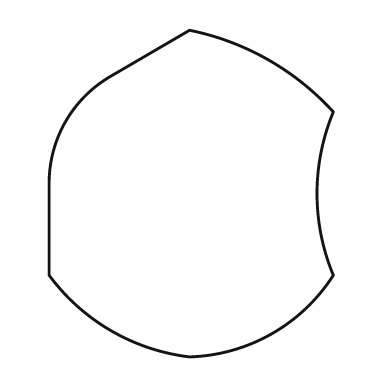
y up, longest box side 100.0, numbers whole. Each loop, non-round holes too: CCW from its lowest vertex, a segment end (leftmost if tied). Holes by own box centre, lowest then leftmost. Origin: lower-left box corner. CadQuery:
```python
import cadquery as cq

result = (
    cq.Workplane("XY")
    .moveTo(43.0, 0.0)
    .threePointArc((68.0, 7.0), (87.0, 25.0))
    .threePointArc((82.0, 50.0), (87.0, 75.0))
    .threePointArc((67.0, 91.0), (43.0, 100.0))
    .lineTo(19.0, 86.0)
    .threePointArc((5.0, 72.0), (0.0, 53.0))
    .lineTo(0.0, 25.0)
    .threePointArc((19.0, 8.0), (43.0, 0.0))
    .close()
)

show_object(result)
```